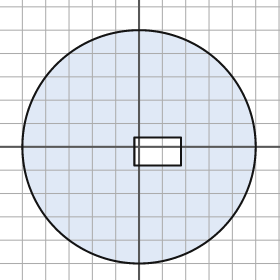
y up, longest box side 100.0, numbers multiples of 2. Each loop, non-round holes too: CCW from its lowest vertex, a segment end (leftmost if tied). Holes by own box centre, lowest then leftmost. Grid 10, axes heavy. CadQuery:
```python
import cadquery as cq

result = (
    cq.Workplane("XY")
    .moveTo(0.0, 0.0)
    .circle(50.0)
    .moveTo(-2.0, -8.0)
    .lineTo(18.0, -8.0)
    .lineTo(18.0, 4.0)
    .lineTo(-2.0, 4.0)
    .close()
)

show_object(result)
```